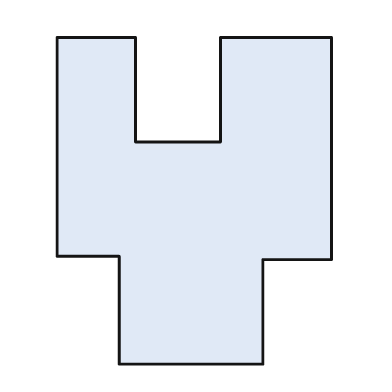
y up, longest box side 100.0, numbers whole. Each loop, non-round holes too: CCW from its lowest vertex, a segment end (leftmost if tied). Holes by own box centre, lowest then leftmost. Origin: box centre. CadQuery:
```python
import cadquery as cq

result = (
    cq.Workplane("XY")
    .moveTo(-23.0, -50.0)
    .lineTo(21.0, -50.0)
    .lineTo(21.0, -18.0)
    .lineTo(42.0, -18.0)
    .lineTo(42.0, 50.0)
    .lineTo(8.0, 50.0)
    .lineTo(8.0, 18.0)
    .lineTo(-18.0, 18.0)
    .lineTo(-18.0, 50.0)
    .lineTo(-42.0, 50.0)
    .lineTo(-42.0, -17.0)
    .lineTo(-23.0, -17.0)
    .close()
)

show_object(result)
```